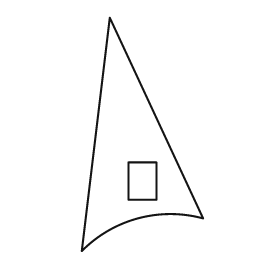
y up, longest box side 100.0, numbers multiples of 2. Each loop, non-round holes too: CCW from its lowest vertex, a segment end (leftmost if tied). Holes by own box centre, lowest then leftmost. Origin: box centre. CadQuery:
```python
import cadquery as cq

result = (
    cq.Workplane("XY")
    .moveTo(-26.0, -50.0)
    .threePointArc((-2.0, -36.0), (26.0, -36.0))
    .lineTo(-14.0, 50.0)
    .close()
    .moveTo(-6.0, -28.0)
    .lineTo(6.0, -28.0)
    .lineTo(6.0, -12.0)
    .lineTo(-6.0, -12.0)
    .close()
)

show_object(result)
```